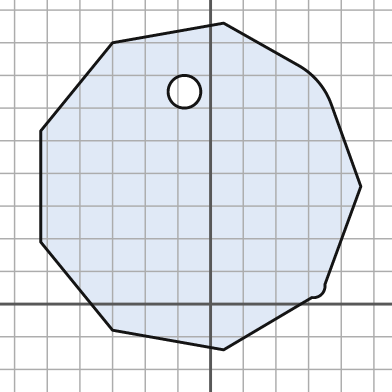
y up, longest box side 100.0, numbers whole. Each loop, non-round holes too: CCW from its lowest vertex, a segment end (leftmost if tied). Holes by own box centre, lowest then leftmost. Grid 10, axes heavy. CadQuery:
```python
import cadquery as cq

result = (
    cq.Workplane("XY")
    .moveTo(4.0, -14.0)
    .lineTo(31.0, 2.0)
    .threePointArc((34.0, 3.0), (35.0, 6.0))
    .lineTo(46.0, 36.0)
    .lineTo(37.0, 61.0)
    .threePointArc((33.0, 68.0), (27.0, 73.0))
    .lineTo(4.0, 86.0)
    .lineTo(-30.0, 80.0)
    .lineTo(-52.0, 53.0)
    .lineTo(-52.0, 19.0)
    .lineTo(-30.0, -8.0)
    .close()
    .moveTo(-8.0, 65.0)
    .circle(5.0)
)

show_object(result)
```